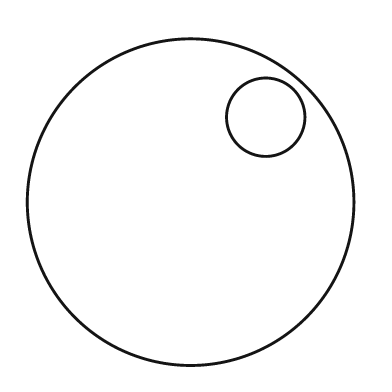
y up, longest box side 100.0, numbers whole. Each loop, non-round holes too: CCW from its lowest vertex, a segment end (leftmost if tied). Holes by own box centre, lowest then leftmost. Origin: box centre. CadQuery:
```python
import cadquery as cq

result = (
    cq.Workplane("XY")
    .moveTo(0.0, 0.0)
    .circle(50.0)
    .moveTo(23.0, 26.0)
    .circle(12.0)
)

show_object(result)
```